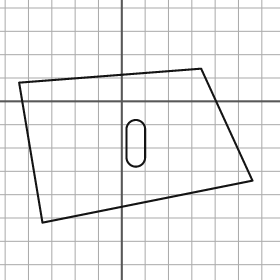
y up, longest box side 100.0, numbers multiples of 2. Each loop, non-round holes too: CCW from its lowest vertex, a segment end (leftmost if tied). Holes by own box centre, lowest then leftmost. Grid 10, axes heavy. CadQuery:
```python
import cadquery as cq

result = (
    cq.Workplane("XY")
    .moveTo(-34.0, -52.0)
    .lineTo(56.0, -34.0)
    .lineTo(34.0, 14.0)
    .lineTo(-44.0, 8.0)
    .close()
    .moveTo(2.0, -24.0)
    .threePointArc((6.0, -28.0), (10.0, -24.0))
    .lineTo(10.0, -12.0)
    .threePointArc((6.0, -8.0), (2.0, -12.0))
    .close()
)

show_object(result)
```